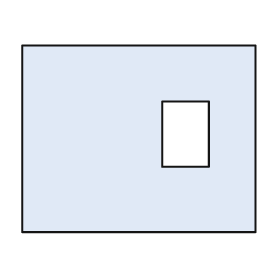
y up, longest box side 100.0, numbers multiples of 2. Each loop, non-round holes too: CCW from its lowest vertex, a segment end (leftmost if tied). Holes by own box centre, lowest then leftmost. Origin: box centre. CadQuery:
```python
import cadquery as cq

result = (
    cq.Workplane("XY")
    .moveTo(-50.0, -40.0)
    .lineTo(50.0, -40.0)
    .lineTo(50.0, 40.0)
    .lineTo(-50.0, 40.0)
    .close()
    .moveTo(10.0, -12.0)
    .lineTo(30.0, -12.0)
    .lineTo(30.0, 16.0)
    .lineTo(10.0, 16.0)
    .close()
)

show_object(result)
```